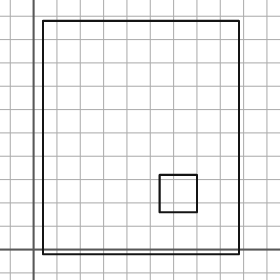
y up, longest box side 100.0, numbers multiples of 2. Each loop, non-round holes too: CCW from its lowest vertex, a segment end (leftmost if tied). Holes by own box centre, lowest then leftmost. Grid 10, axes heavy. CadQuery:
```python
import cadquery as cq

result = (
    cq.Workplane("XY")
    .moveTo(4.0, -2.0)
    .lineTo(88.0, -2.0)
    .lineTo(88.0, 98.0)
    .lineTo(4.0, 98.0)
    .close()
    .moveTo(54.0, 16.0)
    .lineTo(70.0, 16.0)
    .lineTo(70.0, 32.0)
    .lineTo(54.0, 32.0)
    .close()
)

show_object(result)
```